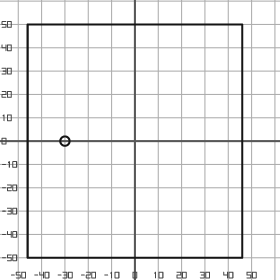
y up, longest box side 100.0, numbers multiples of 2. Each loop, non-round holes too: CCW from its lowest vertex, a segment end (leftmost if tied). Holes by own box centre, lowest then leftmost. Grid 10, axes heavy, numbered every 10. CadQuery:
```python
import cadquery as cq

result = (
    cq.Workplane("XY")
    .moveTo(-46.0, -50.0)
    .lineTo(46.0, -50.0)
    .lineTo(46.0, 50.0)
    .lineTo(-46.0, 50.0)
    .close()
    .moveTo(-30.0, 0.0)
    .circle(2.0)
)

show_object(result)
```